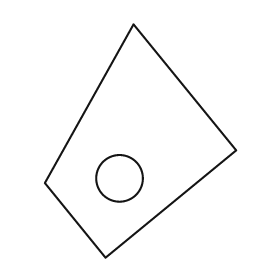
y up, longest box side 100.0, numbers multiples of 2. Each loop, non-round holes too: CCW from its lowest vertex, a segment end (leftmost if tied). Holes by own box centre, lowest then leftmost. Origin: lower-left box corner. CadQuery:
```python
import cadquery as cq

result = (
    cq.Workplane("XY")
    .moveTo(26.0, 0.0)
    .lineTo(82.0, 46.0)
    .lineTo(38.0, 100.0)
    .lineTo(0.0, 32.0)
    .close()
    .moveTo(32.0, 34.0)
    .circle(10.0)
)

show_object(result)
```